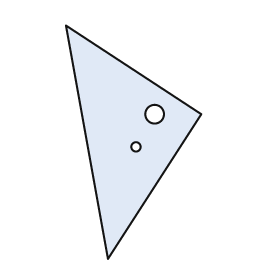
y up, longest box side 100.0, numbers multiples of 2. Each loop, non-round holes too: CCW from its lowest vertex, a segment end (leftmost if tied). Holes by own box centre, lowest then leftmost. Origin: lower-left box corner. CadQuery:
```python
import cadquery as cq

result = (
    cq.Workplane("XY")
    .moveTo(18.0, 0.0)
    .lineTo(58.0, 62.0)
    .lineTo(0.0, 100.0)
    .close()
    .moveTo(30.0, 48.0)
    .circle(2.0)
    .moveTo(38.0, 62.0)
    .circle(4.0)
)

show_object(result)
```